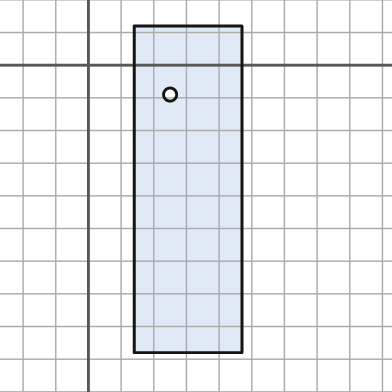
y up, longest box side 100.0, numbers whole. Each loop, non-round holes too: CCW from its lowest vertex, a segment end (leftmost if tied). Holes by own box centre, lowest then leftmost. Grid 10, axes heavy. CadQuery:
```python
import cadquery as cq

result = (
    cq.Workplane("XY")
    .moveTo(14.0, -88.0)
    .lineTo(47.0, -88.0)
    .lineTo(47.0, 12.0)
    .lineTo(14.0, 12.0)
    .close()
    .moveTo(25.0, -9.0)
    .circle(2.0)
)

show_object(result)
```